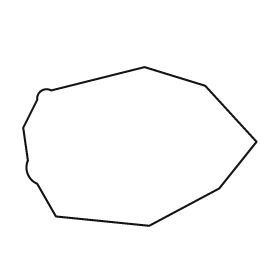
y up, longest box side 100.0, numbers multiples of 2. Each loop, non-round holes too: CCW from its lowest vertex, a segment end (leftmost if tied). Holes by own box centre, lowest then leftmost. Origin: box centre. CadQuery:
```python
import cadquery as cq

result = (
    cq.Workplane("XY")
    .moveTo(4.0, -34.0)
    .lineTo(34.0, -18.0)
    .lineTo(50.0, 2.0)
    .lineTo(28.0, 26.0)
    .lineTo(2.0, 34.0)
    .lineTo(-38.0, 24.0)
    .threePointArc((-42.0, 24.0), (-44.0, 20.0))
    .lineTo(-50.0, 8.0)
    .lineTo(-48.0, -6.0)
    .threePointArc((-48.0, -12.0), (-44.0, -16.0))
    .lineTo(-36.0, -30.0)
    .close()
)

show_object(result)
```